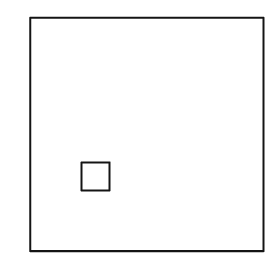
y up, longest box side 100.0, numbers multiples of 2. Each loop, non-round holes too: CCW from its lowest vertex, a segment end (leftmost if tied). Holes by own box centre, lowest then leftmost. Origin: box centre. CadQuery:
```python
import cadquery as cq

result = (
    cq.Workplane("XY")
    .moveTo(-50.0, -50.0)
    .lineTo(50.0, -50.0)
    .lineTo(50.0, 50.0)
    .lineTo(-50.0, 50.0)
    .close()
    .moveTo(-28.0, -24.0)
    .lineTo(-16.0, -24.0)
    .lineTo(-16.0, -12.0)
    .lineTo(-28.0, -12.0)
    .close()
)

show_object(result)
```